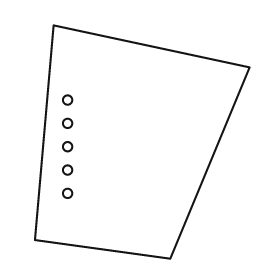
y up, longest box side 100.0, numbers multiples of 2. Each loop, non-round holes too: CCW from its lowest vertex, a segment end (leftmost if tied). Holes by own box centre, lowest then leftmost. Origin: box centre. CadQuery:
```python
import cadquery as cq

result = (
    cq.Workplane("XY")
    .moveTo(12.0, -50.0)
    .lineTo(46.0, 32.0)
    .lineTo(-38.0, 50.0)
    .lineTo(-46.0, -42.0)
    .close()
    .moveTo(-32.0, -22.0)
    .circle(2.0)
    .moveTo(-32.0, -12.0)
    .circle(2.0)
    .moveTo(-32.0, -2.0)
    .circle(2.0)
    .moveTo(-32.0, 8.0)
    .circle(2.0)
    .moveTo(-32.0, 18.0)
    .circle(2.0)
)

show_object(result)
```